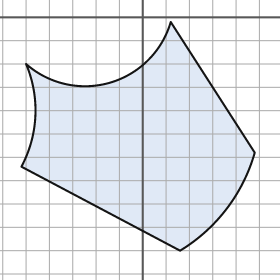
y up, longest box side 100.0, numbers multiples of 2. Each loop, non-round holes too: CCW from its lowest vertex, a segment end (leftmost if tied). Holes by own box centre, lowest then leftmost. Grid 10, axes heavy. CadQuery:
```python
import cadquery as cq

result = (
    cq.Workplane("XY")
    .moveTo(16.0, -100.0)
    .threePointArc((36.0, -82.0), (48.0, -58.0))
    .lineTo(12.0, -2.0)
    .threePointArc((-14.0, -28.0), (-50.0, -20.0))
    .threePointArc((-46.0, -42.0), (-52.0, -64.0))
    .close()
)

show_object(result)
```